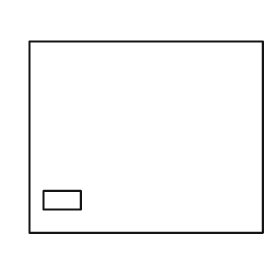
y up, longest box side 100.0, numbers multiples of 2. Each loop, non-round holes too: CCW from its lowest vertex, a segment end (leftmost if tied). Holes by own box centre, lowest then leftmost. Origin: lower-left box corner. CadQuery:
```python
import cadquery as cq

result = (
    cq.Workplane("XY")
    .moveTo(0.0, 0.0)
    .lineTo(100.0, 0.0)
    .lineTo(100.0, 82.0)
    .lineTo(0.0, 82.0)
    .close()
    .moveTo(6.0, 10.0)
    .lineTo(22.0, 10.0)
    .lineTo(22.0, 18.0)
    .lineTo(6.0, 18.0)
    .close()
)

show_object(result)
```